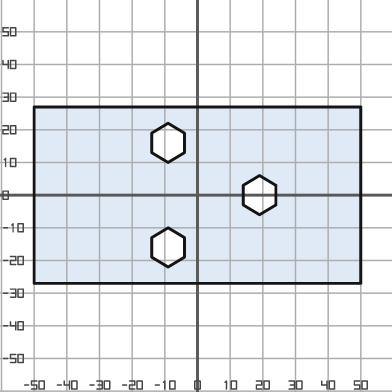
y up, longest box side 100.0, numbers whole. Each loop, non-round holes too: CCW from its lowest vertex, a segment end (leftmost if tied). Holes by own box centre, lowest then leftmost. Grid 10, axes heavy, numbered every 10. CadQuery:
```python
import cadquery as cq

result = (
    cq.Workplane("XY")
    .moveTo(-50.0, -27.0)
    .lineTo(50.0, -27.0)
    .lineTo(50.0, 27.0)
    .lineTo(-50.0, 27.0)
    .close()
    .moveTo(-9.0, -22.0)
    .lineTo(-4.0, -19.0)
    .lineTo(-4.0, -13.0)
    .lineTo(-9.0, -10.0)
    .lineTo(-14.0, -13.0)
    .lineTo(-14.0, -19.0)
    .close()
    .moveTo(19.0, -6.0)
    .lineTo(24.0, -3.0)
    .lineTo(24.0, 3.0)
    .lineTo(19.0, 6.0)
    .lineTo(14.0, 3.0)
    .lineTo(14.0, -3.0)
    .close()
    .moveTo(-9.0, 10.0)
    .lineTo(-4.0, 13.0)
    .lineTo(-4.0, 19.0)
    .lineTo(-9.0, 22.0)
    .lineTo(-14.0, 19.0)
    .lineTo(-14.0, 13.0)
    .close()
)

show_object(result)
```